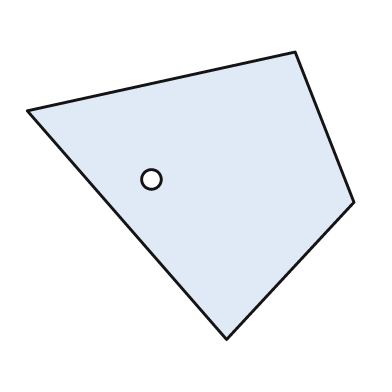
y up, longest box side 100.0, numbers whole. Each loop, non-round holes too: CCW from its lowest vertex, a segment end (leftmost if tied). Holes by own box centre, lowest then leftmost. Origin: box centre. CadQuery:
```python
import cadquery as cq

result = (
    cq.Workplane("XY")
    .moveTo(11.0, -44.0)
    .lineTo(50.0, -2.0)
    .lineTo(32.0, 44.0)
    .lineTo(-50.0, 26.0)
    .close()
    .moveTo(-12.0, 5.0)
    .circle(3.0)
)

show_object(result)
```